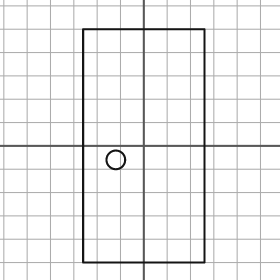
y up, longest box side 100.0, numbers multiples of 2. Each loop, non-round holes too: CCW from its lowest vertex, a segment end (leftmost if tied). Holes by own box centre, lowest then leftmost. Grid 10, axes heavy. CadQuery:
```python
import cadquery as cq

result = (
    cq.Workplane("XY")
    .moveTo(-26.0, -50.0)
    .lineTo(26.0, -50.0)
    .lineTo(26.0, 50.0)
    .lineTo(-26.0, 50.0)
    .close()
    .moveTo(-12.0, -6.0)
    .circle(4.0)
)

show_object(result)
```